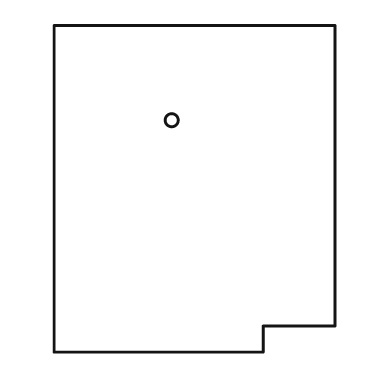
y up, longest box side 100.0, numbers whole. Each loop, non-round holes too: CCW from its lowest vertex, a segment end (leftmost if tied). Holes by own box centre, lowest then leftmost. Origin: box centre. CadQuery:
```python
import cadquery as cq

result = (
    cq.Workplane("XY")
    .moveTo(-43.0, -50.0)
    .lineTo(21.0, -50.0)
    .lineTo(21.0, -42.0)
    .lineTo(43.0, -42.0)
    .lineTo(43.0, 50.0)
    .lineTo(-43.0, 50.0)
    .close()
    .moveTo(-7.0, 21.0)
    .circle(2.0)
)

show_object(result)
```